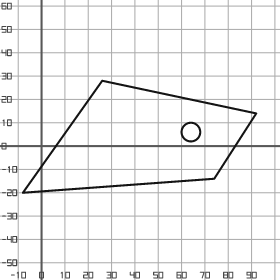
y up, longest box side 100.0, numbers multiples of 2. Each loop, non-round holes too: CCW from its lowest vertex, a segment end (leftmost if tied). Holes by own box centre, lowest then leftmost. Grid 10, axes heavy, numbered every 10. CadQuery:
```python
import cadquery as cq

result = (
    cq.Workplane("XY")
    .moveTo(-8.0, -20.0)
    .lineTo(74.0, -14.0)
    .lineTo(92.0, 14.0)
    .lineTo(26.0, 28.0)
    .close()
    .moveTo(64.0, 6.0)
    .circle(4.0)
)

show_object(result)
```